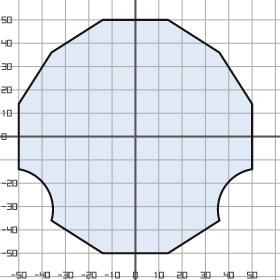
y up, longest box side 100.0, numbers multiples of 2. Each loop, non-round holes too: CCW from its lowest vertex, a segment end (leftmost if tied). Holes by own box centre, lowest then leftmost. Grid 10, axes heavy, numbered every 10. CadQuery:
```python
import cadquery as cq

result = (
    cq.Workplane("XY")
    .moveTo(-14.0, -50.0)
    .lineTo(14.0, -50.0)
    .lineTo(36.0, -36.0)
    .threePointArc((38.0, -22.0), (50.0, -14.0))
    .lineTo(50.0, 14.0)
    .lineTo(36.0, 36.0)
    .lineTo(14.0, 50.0)
    .lineTo(-14.0, 50.0)
    .lineTo(-36.0, 36.0)
    .lineTo(-50.0, 14.0)
    .lineTo(-50.0, -14.0)
    .threePointArc((-38.0, -22.0), (-36.0, -36.0))
    .close()
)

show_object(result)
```